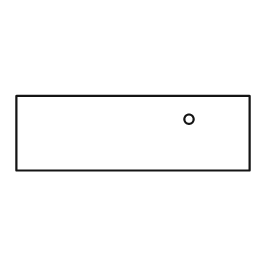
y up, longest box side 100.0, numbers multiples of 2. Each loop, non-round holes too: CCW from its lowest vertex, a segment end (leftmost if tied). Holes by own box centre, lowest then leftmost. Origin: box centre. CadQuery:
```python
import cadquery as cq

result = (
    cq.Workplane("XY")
    .moveTo(-50.0, -16.0)
    .lineTo(50.0, -16.0)
    .lineTo(50.0, 16.0)
    .lineTo(-50.0, 16.0)
    .close()
    .moveTo(24.0, 6.0)
    .circle(2.0)
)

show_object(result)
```